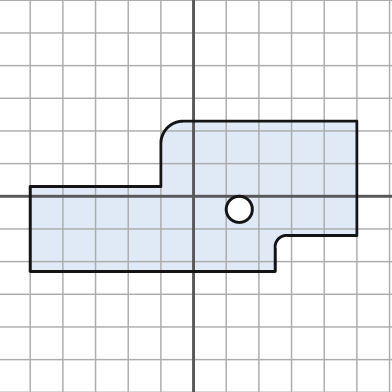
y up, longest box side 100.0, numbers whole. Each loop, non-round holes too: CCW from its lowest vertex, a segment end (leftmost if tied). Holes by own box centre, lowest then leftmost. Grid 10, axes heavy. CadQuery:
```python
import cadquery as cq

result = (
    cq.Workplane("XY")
    .moveTo(-50.0, -23.0)
    .lineTo(25.0, -23.0)
    .lineTo(25.0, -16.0)
    .threePointArc((26.0, -13.0), (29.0, -12.0))
    .lineTo(50.0, -12.0)
    .lineTo(50.0, 23.0)
    .lineTo(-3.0, 23.0)
    .threePointArc((-8.0, 21.0), (-10.0, 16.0))
    .lineTo(-10.0, 3.0)
    .lineTo(-50.0, 3.0)
    .close()
    .moveTo(14.0, -4.0)
    .circle(4.0)
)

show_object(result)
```